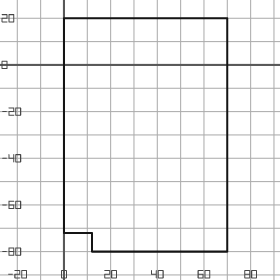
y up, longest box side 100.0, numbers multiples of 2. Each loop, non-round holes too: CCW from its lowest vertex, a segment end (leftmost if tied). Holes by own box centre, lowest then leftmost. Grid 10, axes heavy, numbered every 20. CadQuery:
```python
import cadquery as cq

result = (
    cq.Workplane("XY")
    .moveTo(12.0, -80.0)
    .lineTo(70.0, -80.0)
    .lineTo(70.0, 20.0)
    .lineTo(0.0, 20.0)
    .lineTo(0.0, -72.0)
    .lineTo(12.0, -72.0)
    .close()
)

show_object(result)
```